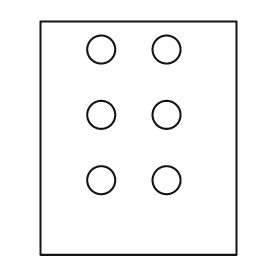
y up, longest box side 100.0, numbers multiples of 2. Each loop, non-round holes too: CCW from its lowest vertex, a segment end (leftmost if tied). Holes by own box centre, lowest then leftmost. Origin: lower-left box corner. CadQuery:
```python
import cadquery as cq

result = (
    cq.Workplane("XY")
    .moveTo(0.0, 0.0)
    .lineTo(84.0, 0.0)
    .lineTo(84.0, 100.0)
    .lineTo(0.0, 100.0)
    .close()
    .moveTo(26.0, 32.0)
    .circle(6.0)
    .moveTo(54.0, 32.0)
    .circle(6.0)
    .moveTo(26.0, 60.0)
    .circle(6.0)
    .moveTo(54.0, 60.0)
    .circle(6.0)
    .moveTo(26.0, 88.0)
    .circle(6.0)
    .moveTo(54.0, 88.0)
    .circle(6.0)
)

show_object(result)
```